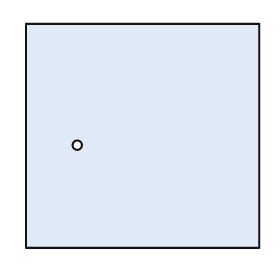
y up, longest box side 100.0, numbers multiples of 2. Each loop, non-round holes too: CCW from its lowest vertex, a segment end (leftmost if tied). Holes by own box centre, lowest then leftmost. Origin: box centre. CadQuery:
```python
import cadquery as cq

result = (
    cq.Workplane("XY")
    .moveTo(-50.0, -48.0)
    .lineTo(50.0, -48.0)
    .lineTo(50.0, 48.0)
    .lineTo(-50.0, 48.0)
    .close()
    .moveTo(-28.0, -4.0)
    .circle(2.0)
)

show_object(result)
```